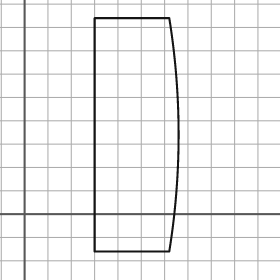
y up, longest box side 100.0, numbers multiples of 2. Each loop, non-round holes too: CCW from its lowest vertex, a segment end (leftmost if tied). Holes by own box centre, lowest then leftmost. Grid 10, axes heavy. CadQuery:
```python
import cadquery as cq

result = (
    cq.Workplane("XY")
    .moveTo(30.0, -16.0)
    .lineTo(62.0, -16.0)
    .threePointArc((66.0, 34.0), (62.0, 84.0))
    .lineTo(30.0, 84.0)
    .close()
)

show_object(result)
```